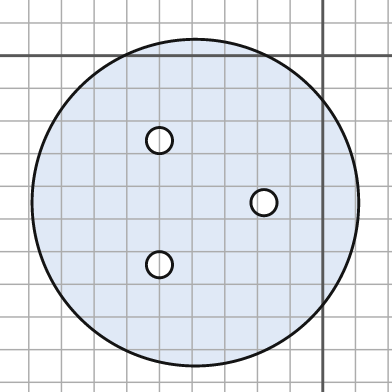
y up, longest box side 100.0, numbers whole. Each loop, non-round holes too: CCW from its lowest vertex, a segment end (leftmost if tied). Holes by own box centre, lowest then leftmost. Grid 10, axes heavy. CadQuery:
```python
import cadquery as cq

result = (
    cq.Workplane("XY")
    .moveTo(-39.0, -45.0)
    .circle(50.0)
    .moveTo(-50.0, -64.0)
    .circle(4.0)
    .moveTo(-18.0, -45.0)
    .circle(4.0)
    .moveTo(-50.0, -26.0)
    .circle(4.0)
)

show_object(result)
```